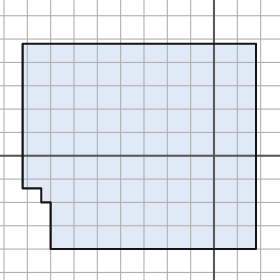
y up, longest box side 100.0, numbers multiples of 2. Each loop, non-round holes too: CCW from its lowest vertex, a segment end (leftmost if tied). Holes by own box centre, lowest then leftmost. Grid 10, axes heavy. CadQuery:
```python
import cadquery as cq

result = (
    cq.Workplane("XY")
    .moveTo(-70.0, -40.0)
    .lineTo(18.0, -40.0)
    .lineTo(18.0, 48.0)
    .lineTo(-82.0, 48.0)
    .lineTo(-82.0, -14.0)
    .lineTo(-74.0, -14.0)
    .lineTo(-74.0, -20.0)
    .lineTo(-70.0, -20.0)
    .close()
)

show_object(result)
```